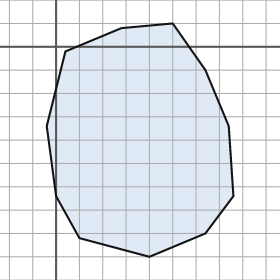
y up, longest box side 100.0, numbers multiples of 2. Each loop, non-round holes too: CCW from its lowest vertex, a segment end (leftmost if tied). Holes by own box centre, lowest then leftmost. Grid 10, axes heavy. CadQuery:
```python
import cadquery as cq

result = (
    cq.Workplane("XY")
    .moveTo(40.0, -90.0)
    .lineTo(64.0, -80.0)
    .lineTo(76.0, -64.0)
    .lineTo(74.0, -34.0)
    .lineTo(64.0, -10.0)
    .lineTo(50.0, 10.0)
    .lineTo(28.0, 8.0)
    .lineTo(4.0, -2.0)
    .lineTo(-4.0, -34.0)
    .lineTo(0.0, -64.0)
    .lineTo(10.0, -82.0)
    .close()
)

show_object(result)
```